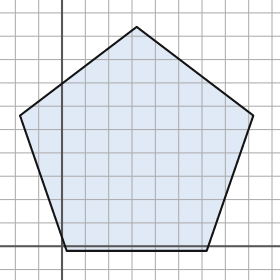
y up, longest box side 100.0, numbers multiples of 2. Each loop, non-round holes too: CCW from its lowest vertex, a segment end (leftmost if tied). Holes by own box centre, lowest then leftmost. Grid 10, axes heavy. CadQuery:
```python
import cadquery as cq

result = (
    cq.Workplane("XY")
    .moveTo(2.0, -2.0)
    .lineTo(62.0, -2.0)
    .lineTo(82.0, 56.0)
    .lineTo(32.0, 94.0)
    .lineTo(-18.0, 56.0)
    .close()
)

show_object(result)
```